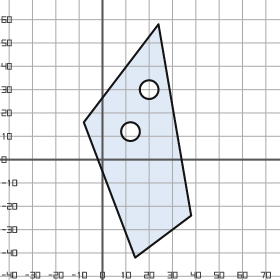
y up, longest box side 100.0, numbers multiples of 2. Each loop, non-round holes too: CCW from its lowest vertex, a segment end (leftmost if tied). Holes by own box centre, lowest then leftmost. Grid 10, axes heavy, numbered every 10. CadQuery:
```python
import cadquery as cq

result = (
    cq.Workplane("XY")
    .moveTo(14.0, -42.0)
    .lineTo(38.0, -24.0)
    .lineTo(24.0, 58.0)
    .lineTo(-8.0, 16.0)
    .close()
    .moveTo(12.0, 12.0)
    .circle(4.0)
    .moveTo(20.0, 30.0)
    .circle(4.0)
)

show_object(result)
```